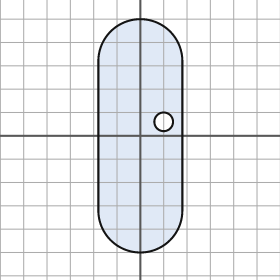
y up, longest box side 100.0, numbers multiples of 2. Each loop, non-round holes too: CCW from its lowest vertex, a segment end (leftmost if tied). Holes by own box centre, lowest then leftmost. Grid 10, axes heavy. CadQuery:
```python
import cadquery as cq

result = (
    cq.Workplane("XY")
    .moveTo(-18.0, -32.0)
    .threePointArc((0.0, -50.0), (18.0, -32.0))
    .lineTo(18.0, 32.0)
    .threePointArc((0.0, 50.0), (-18.0, 32.0))
    .close()
    .moveTo(10.0, 6.0)
    .circle(4.0)
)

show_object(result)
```